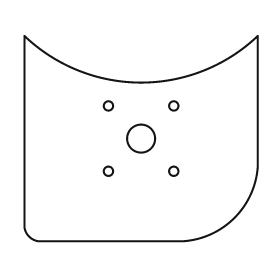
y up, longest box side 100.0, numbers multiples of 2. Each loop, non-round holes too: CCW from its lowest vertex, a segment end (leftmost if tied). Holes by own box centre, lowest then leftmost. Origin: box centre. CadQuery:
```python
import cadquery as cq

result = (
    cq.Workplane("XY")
    .moveTo(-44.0, -44.0)
    .lineTo(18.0, -44.0)
    .threePointArc((40.0, -34.0), (50.0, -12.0))
    .lineTo(50.0, 44.0)
    .threePointArc((0.0, 24.0), (-50.0, 44.0))
    .lineTo(-50.0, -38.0)
    .threePointArc((-48.0, -42.0), (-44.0, -44.0))
    .close()
    .moveTo(-14.0, -14.0)
    .circle(2.0)
    .moveTo(14.0, -14.0)
    .circle(2.0)
    .moveTo(0.0, 0.0)
    .circle(6.0)
    .moveTo(-14.0, 14.0)
    .circle(2.0)
    .moveTo(14.0, 14.0)
    .circle(2.0)
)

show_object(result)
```